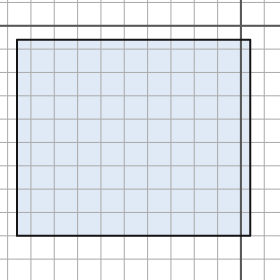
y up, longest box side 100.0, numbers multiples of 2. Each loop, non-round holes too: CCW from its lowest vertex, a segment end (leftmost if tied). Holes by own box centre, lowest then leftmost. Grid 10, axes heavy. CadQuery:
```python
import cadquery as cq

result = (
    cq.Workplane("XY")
    .moveTo(-96.0, -90.0)
    .lineTo(4.0, -90.0)
    .lineTo(4.0, -6.0)
    .lineTo(-96.0, -6.0)
    .close()
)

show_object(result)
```